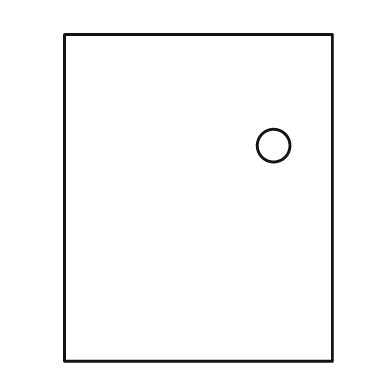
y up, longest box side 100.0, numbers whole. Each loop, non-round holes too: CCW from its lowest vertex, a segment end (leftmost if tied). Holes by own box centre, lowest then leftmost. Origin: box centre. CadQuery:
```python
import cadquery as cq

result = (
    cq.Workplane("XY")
    .moveTo(-41.0, -50.0)
    .lineTo(41.0, -50.0)
    .lineTo(41.0, 50.0)
    .lineTo(-41.0, 50.0)
    .close()
    .moveTo(23.0, 16.0)
    .circle(5.0)
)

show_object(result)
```